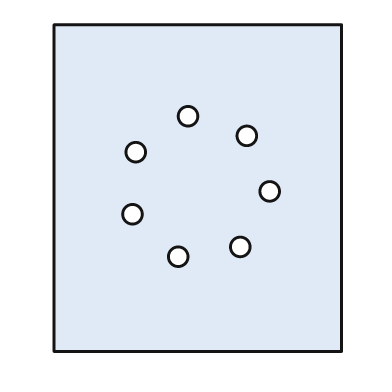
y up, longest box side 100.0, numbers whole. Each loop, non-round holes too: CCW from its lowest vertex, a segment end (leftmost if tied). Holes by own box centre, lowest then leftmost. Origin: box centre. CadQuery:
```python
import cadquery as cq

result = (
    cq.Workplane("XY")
    .moveTo(-44.0, -50.0)
    .lineTo(44.0, -50.0)
    .lineTo(44.0, 50.0)
    .lineTo(-44.0, 50.0)
    .close()
    .moveTo(-6.0, -21.0)
    .circle(3.0)
    .moveTo(13.0, -18.0)
    .circle(3.0)
    .moveTo(-20.0, -8.0)
    .circle(3.0)
    .moveTo(22.0, -1.0)
    .circle(3.0)
    .moveTo(-19.0, 11.0)
    .circle(3.0)
    .moveTo(15.0, 16.0)
    .circle(3.0)
    .moveTo(-3.0, 22.0)
    .circle(3.0)
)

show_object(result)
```